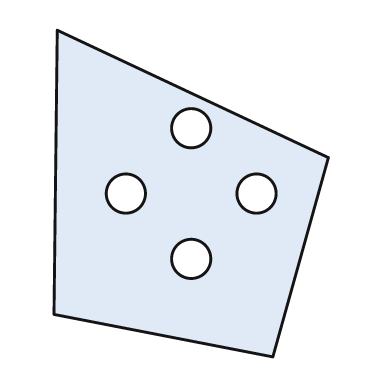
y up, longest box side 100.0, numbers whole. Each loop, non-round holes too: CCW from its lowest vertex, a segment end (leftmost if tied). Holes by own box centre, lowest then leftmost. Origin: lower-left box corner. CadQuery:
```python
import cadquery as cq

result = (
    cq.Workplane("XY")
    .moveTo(67.0, 0.0)
    .lineTo(84.0, 61.0)
    .lineTo(1.0, 100.0)
    .lineTo(0.0, 13.0)
    .close()
    .moveTo(42.0, 30.0)
    .circle(6.0)
    .moveTo(22.0, 50.0)
    .circle(6.0)
    .moveTo(62.0, 50.0)
    .circle(6.0)
    .moveTo(42.0, 70.0)
    .circle(6.0)
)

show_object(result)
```